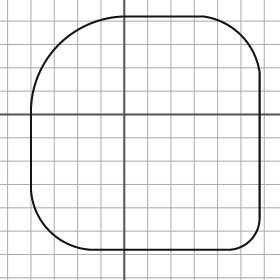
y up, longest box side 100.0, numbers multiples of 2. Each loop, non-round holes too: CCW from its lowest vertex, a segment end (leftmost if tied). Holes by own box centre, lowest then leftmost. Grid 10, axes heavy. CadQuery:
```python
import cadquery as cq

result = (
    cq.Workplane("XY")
    .moveTo(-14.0, -58.0)
    .lineTo(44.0, -58.0)
    .threePointArc((54.0, -54.0), (58.0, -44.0))
    .lineTo(58.0, 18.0)
    .threePointArc((50.0, 34.0), (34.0, 42.0))
    .lineTo(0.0, 42.0)
    .threePointArc((-28.0, 30.0), (-40.0, 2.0))
    .lineTo(-40.0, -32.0)
    .threePointArc((-32.0, -50.0), (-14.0, -58.0))
    .close()
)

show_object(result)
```